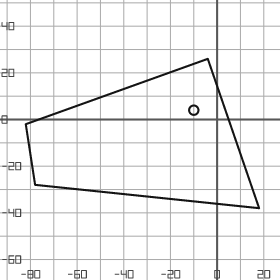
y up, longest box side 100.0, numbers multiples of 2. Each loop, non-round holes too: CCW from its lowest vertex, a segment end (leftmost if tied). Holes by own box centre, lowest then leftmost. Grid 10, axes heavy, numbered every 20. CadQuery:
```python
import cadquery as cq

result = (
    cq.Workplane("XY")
    .moveTo(18.0, -38.0)
    .lineTo(-4.0, 26.0)
    .lineTo(-82.0, -2.0)
    .lineTo(-78.0, -28.0)
    .close()
    .moveTo(-10.0, 4.0)
    .circle(2.0)
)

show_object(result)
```